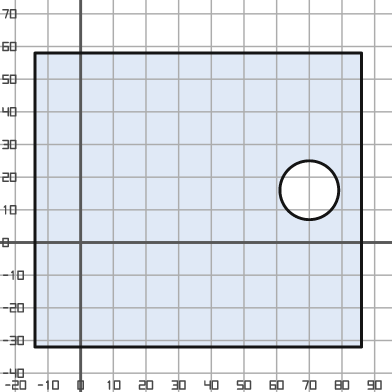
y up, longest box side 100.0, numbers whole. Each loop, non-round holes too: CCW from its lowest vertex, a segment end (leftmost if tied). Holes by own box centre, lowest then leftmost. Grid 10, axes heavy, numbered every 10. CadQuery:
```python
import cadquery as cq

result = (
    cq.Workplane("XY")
    .moveTo(-14.0, -32.0)
    .lineTo(86.0, -32.0)
    .lineTo(86.0, 58.0)
    .lineTo(-14.0, 58.0)
    .close()
    .moveTo(70.0, 16.0)
    .circle(9.0)
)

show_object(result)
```